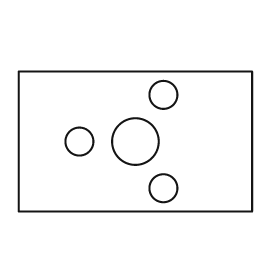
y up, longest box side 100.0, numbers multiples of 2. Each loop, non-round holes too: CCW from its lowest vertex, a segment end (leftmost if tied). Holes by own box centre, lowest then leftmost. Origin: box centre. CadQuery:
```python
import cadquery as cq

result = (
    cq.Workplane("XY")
    .moveTo(-50.0, -30.0)
    .lineTo(50.0, -30.0)
    .lineTo(50.0, 30.0)
    .lineTo(-50.0, 30.0)
    .close()
    .moveTo(12.0, -20.0)
    .circle(6.0)
    .moveTo(-24.0, 0.0)
    .circle(6.0)
    .moveTo(0.0, 0.0)
    .circle(10.0)
    .moveTo(12.0, 20.0)
    .circle(6.0)
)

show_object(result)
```